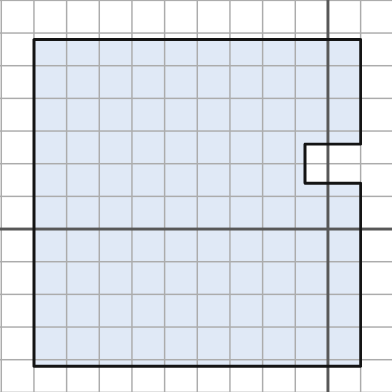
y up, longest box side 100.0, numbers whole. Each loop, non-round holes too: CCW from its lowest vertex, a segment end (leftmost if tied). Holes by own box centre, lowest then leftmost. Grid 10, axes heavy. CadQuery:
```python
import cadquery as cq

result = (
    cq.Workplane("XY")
    .moveTo(-90.0, -42.0)
    .lineTo(10.0, -42.0)
    .lineTo(10.0, 14.0)
    .lineTo(-7.0, 14.0)
    .lineTo(-7.0, 26.0)
    .lineTo(10.0, 26.0)
    .lineTo(10.0, 58.0)
    .lineTo(-90.0, 58.0)
    .close()
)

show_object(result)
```